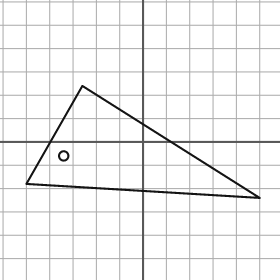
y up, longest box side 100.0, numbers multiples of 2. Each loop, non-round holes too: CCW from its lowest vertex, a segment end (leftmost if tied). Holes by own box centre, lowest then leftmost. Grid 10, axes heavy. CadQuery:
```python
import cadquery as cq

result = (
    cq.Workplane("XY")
    .moveTo(50.0, -24.0)
    .lineTo(-26.0, 24.0)
    .lineTo(-50.0, -18.0)
    .close()
    .moveTo(-34.0, -6.0)
    .circle(2.0)
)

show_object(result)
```